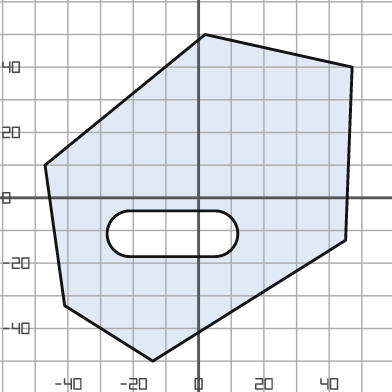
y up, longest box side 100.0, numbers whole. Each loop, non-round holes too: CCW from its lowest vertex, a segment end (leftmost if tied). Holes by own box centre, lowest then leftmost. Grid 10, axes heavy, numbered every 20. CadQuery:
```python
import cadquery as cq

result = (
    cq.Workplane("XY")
    .moveTo(-14.0, -50.0)
    .lineTo(45.0, -13.0)
    .lineTo(47.0, 40.0)
    .lineTo(2.0, 50.0)
    .lineTo(-47.0, 10.0)
    .lineTo(-41.0, -33.0)
    .close()
    .moveTo(-21.0, -18.0)
    .lineTo(5.0, -18.0)
    .threePointArc((12.0, -11.0), (5.0, -4.0))
    .lineTo(-21.0, -4.0)
    .threePointArc((-28.0, -11.0), (-21.0, -18.0))
    .close()
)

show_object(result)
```